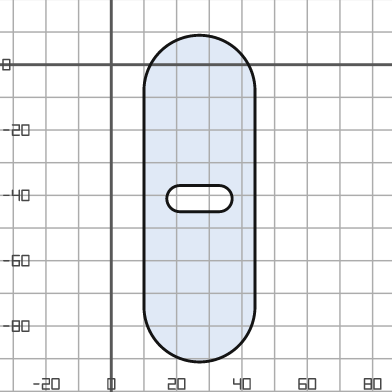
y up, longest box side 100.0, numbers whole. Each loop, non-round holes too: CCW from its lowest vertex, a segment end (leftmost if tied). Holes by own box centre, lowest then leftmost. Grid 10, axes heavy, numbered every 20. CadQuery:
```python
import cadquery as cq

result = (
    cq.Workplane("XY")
    .moveTo(10.0, -74.0)
    .threePointArc((27.0, -91.0), (44.0, -74.0))
    .lineTo(44.0, -8.0)
    .threePointArc((27.0, 9.0), (10.0, -8.0))
    .close()
    .moveTo(21.0, -45.0)
    .lineTo(33.0, -45.0)
    .threePointArc((37.0, -41.0), (33.0, -37.0))
    .lineTo(21.0, -37.0)
    .threePointArc((17.0, -41.0), (21.0, -45.0))
    .close()
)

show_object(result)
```